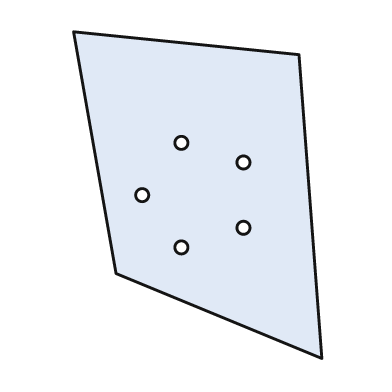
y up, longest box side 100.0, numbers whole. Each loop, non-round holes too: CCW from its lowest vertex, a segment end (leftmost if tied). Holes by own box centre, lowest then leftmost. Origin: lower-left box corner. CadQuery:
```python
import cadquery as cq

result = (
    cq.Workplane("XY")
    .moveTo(76.0, 0.0)
    .lineTo(69.0, 93.0)
    .lineTo(0.0, 100.0)
    .lineTo(13.0, 26.0)
    .close()
    .moveTo(33.0, 34.0)
    .circle(2.0)
    .moveTo(52.0, 40.0)
    .circle(2.0)
    .moveTo(21.0, 50.0)
    .circle(2.0)
    .moveTo(52.0, 60.0)
    .circle(2.0)
    .moveTo(33.0, 66.0)
    .circle(2.0)
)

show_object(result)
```